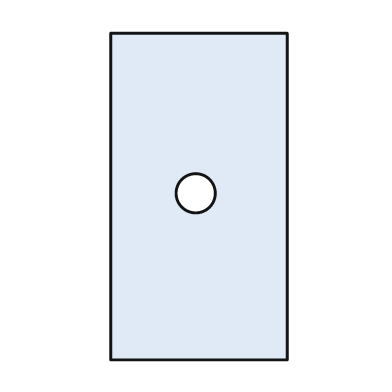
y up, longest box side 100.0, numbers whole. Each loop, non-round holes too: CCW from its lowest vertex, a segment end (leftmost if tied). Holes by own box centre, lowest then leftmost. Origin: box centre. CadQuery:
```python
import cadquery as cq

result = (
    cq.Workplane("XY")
    .moveTo(-27.0, -50.0)
    .lineTo(27.0, -50.0)
    .lineTo(27.0, 50.0)
    .lineTo(-27.0, 50.0)
    .close()
    .moveTo(-1.0, 1.0)
    .circle(6.0)
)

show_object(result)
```